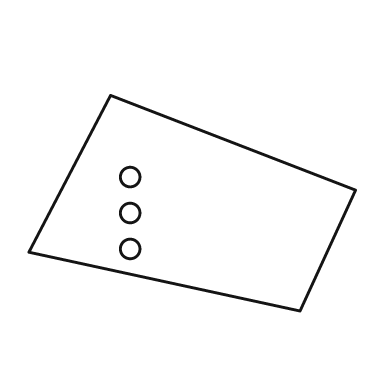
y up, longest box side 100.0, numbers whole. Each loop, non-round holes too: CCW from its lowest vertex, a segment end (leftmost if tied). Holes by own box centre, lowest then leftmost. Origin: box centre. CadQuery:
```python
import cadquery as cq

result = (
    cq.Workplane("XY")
    .moveTo(33.0, -33.0)
    .lineTo(50.0, 4.0)
    .lineTo(-25.0, 33.0)
    .lineTo(-50.0, -15.0)
    .close()
    .moveTo(-19.0, -14.0)
    .circle(3.0)
    .moveTo(-19.0, -3.0)
    .circle(3.0)
    .moveTo(-19.0, 8.0)
    .circle(3.0)
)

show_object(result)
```